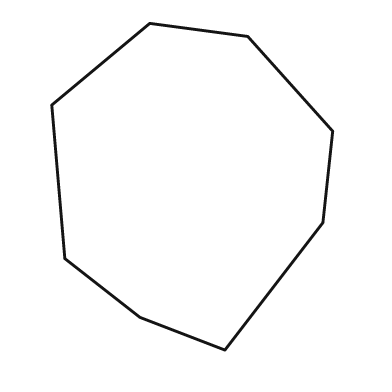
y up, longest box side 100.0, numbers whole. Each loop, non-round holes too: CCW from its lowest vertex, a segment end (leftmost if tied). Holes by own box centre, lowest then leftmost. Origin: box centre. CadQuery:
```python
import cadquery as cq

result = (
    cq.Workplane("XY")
    .moveTo(10.0, -50.0)
    .lineTo(40.0, -11.0)
    .lineTo(43.0, 17.0)
    .lineTo(17.0, 46.0)
    .lineTo(-13.0, 50.0)
    .lineTo(-43.0, 25.0)
    .lineTo(-39.0, -22.0)
    .lineTo(-16.0, -40.0)
    .close()
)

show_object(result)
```